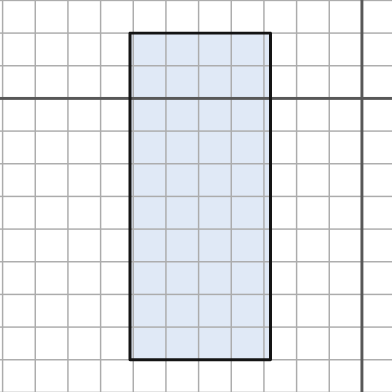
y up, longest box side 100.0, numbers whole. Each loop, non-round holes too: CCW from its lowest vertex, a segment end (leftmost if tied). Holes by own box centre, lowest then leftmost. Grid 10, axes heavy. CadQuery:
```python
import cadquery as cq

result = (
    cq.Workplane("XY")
    .moveTo(-71.0, -80.0)
    .lineTo(-28.0, -80.0)
    .lineTo(-28.0, 20.0)
    .lineTo(-71.0, 20.0)
    .close()
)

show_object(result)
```